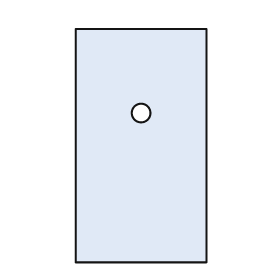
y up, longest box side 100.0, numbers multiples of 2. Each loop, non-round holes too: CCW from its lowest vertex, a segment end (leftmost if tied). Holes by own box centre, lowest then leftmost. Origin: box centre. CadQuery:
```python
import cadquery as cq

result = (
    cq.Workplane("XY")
    .moveTo(-28.0, -50.0)
    .lineTo(28.0, -50.0)
    .lineTo(28.0, 50.0)
    .lineTo(-28.0, 50.0)
    .close()
    .moveTo(0.0, 14.0)
    .circle(4.0)
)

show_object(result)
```